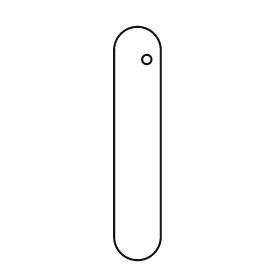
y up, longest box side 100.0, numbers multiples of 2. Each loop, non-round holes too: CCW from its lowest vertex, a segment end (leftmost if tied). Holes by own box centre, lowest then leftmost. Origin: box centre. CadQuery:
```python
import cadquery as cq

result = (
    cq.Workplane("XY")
    .moveTo(-10.0, -40.0)
    .threePointArc((0.0, -50.0), (10.0, -40.0))
    .lineTo(10.0, 40.0)
    .threePointArc((0.0, 50.0), (-10.0, 40.0))
    .close()
    .moveTo(4.0, 36.0)
    .circle(2.0)
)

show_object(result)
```